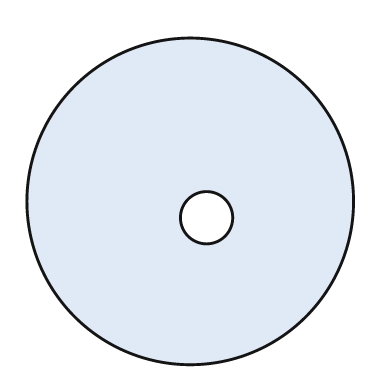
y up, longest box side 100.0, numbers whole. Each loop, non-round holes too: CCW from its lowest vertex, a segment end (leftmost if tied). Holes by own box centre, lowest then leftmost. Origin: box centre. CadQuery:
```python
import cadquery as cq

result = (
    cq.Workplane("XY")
    .moveTo(0.0, 0.0)
    .circle(50.0)
    .moveTo(5.0, -5.0)
    .circle(8.0)
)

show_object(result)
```